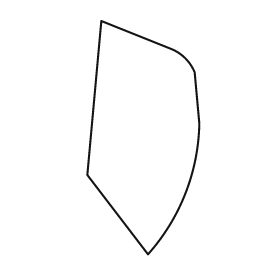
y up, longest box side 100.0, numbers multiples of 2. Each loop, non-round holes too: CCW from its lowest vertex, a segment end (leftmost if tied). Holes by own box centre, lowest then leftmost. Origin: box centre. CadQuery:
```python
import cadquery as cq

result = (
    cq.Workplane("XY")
    .moveTo(2.0, -50.0)
    .threePointArc((18.0, -24.0), (24.0, 6.0))
    .lineTo(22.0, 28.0)
    .threePointArc((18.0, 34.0), (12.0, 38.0))
    .lineTo(-18.0, 50.0)
    .lineTo(-24.0, -16.0)
    .close()
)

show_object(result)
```